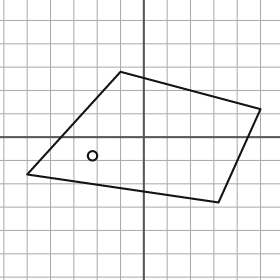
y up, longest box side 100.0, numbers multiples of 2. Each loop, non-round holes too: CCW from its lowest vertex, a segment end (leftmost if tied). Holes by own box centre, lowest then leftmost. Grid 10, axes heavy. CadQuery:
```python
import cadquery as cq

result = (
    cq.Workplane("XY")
    .moveTo(32.0, -28.0)
    .lineTo(50.0, 12.0)
    .lineTo(-10.0, 28.0)
    .lineTo(-50.0, -16.0)
    .close()
    .moveTo(-22.0, -8.0)
    .circle(2.0)
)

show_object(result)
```